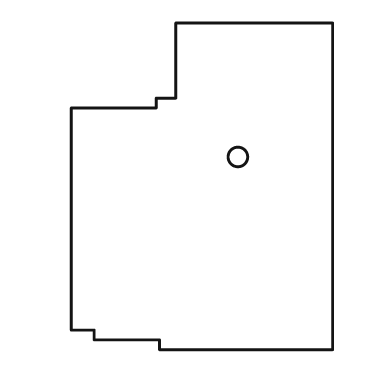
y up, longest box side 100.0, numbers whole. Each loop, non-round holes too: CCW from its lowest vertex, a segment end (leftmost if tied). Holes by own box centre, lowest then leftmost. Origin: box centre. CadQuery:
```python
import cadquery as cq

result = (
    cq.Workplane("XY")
    .moveTo(-13.0, -50.0)
    .lineTo(40.0, -50.0)
    .lineTo(40.0, 50.0)
    .lineTo(-8.0, 50.0)
    .lineTo(-8.0, 27.0)
    .lineTo(-14.0, 27.0)
    .lineTo(-14.0, 24.0)
    .lineTo(-40.0, 24.0)
    .lineTo(-40.0, -44.0)
    .lineTo(-33.0, -44.0)
    .lineTo(-33.0, -47.0)
    .lineTo(-13.0, -47.0)
    .close()
    .moveTo(11.0, 9.0)
    .circle(3.0)
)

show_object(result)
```